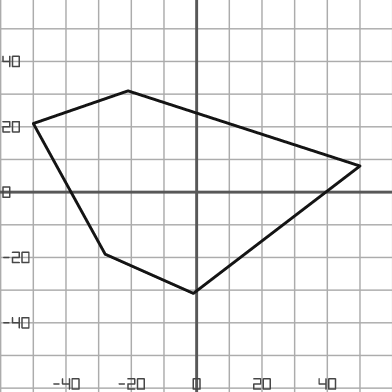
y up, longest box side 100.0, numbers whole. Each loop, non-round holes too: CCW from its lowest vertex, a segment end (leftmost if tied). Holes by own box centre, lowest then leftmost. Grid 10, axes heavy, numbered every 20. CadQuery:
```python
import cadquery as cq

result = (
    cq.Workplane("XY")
    .moveTo(-1.0, -31.0)
    .lineTo(50.0, 8.0)
    .lineTo(-21.0, 31.0)
    .lineTo(-50.0, 21.0)
    .lineTo(-28.0, -19.0)
    .close()
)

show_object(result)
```